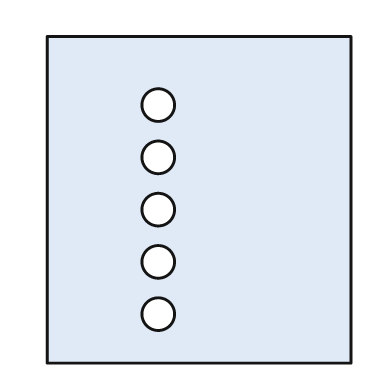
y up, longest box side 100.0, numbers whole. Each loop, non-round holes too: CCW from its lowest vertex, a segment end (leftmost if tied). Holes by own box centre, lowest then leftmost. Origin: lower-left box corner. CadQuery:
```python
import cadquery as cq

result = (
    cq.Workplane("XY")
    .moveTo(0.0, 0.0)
    .lineTo(93.0, 0.0)
    .lineTo(93.0, 100.0)
    .lineTo(0.0, 100.0)
    .close()
    .moveTo(34.0, 15.0)
    .circle(5.0)
    .moveTo(34.0, 31.0)
    .circle(5.0)
    .moveTo(34.0, 47.0)
    .circle(5.0)
    .moveTo(34.0, 63.0)
    .circle(5.0)
    .moveTo(34.0, 79.0)
    .circle(5.0)
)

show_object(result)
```